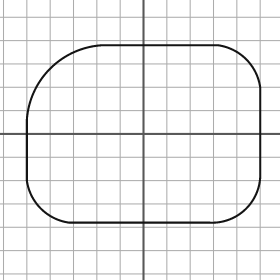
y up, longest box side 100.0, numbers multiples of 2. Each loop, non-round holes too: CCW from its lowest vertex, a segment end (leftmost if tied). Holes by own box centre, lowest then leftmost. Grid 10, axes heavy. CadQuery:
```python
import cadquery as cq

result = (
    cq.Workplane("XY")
    .moveTo(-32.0, -38.0)
    .lineTo(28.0, -38.0)
    .threePointArc((44.0, -32.0), (50.0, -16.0))
    .lineTo(50.0, 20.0)
    .threePointArc((44.0, 32.0), (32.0, 38.0))
    .lineTo(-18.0, 38.0)
    .threePointArc((-40.0, 28.0), (-50.0, 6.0))
    .lineTo(-50.0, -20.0)
    .threePointArc((-44.0, -32.0), (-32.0, -38.0))
    .close()
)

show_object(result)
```